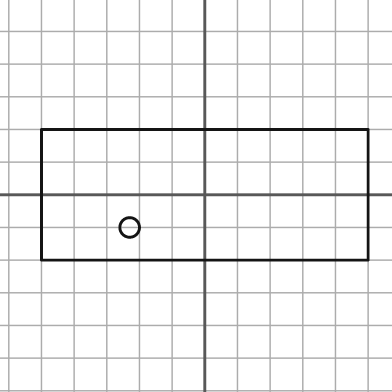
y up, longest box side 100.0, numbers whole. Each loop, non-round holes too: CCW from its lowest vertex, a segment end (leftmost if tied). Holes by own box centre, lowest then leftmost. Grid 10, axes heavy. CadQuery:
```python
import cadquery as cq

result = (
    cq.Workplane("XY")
    .moveTo(-50.0, -20.0)
    .lineTo(50.0, -20.0)
    .lineTo(50.0, 20.0)
    .lineTo(-50.0, 20.0)
    .close()
    .moveTo(-23.0, -10.0)
    .circle(3.0)
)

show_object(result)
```